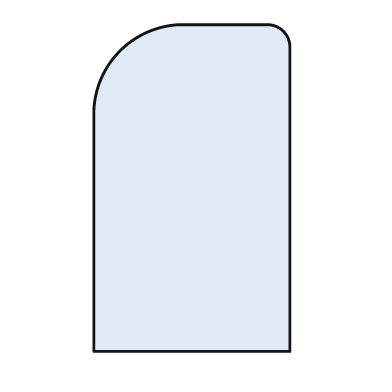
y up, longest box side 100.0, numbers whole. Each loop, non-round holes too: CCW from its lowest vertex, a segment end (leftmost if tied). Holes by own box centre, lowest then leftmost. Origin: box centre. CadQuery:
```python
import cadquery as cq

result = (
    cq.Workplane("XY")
    .moveTo(-30.0, -50.0)
    .lineTo(30.0, -50.0)
    .lineTo(30.0, 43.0)
    .threePointArc((28.0, 48.0), (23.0, 50.0))
    .lineTo(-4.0, 50.0)
    .threePointArc((-22.0, 42.0), (-30.0, 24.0))
    .close()
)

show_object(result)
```